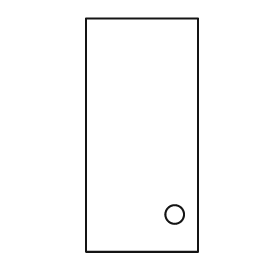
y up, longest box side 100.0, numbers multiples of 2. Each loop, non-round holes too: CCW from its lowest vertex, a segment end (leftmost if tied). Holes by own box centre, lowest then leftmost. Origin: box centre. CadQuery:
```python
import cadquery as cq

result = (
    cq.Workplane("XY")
    .moveTo(-24.0, -50.0)
    .lineTo(24.0, -50.0)
    .lineTo(24.0, 50.0)
    .lineTo(-24.0, 50.0)
    .close()
    .moveTo(14.0, -34.0)
    .circle(4.0)
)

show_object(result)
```